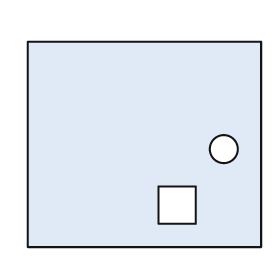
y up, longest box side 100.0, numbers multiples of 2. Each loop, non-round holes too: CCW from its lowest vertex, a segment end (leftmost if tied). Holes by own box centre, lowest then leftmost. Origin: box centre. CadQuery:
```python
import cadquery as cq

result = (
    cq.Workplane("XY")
    .moveTo(-50.0, -44.0)
    .lineTo(50.0, -44.0)
    .lineTo(50.0, 44.0)
    .lineTo(-50.0, 44.0)
    .close()
    .moveTo(6.0, -34.0)
    .lineTo(22.0, -34.0)
    .lineTo(22.0, -18.0)
    .lineTo(6.0, -18.0)
    .close()
    .moveTo(34.0, -2.0)
    .circle(6.0)
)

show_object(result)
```